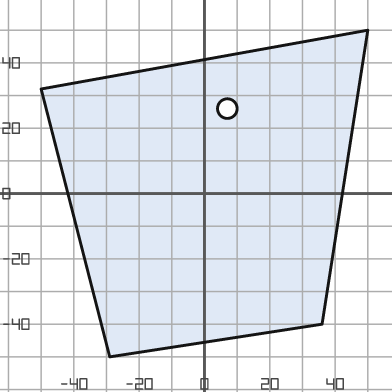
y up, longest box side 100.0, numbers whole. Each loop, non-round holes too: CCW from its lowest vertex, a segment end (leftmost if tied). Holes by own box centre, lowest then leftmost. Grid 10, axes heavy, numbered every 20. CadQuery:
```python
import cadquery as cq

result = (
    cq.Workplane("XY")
    .moveTo(-29.0, -50.0)
    .lineTo(36.0, -40.0)
    .lineTo(50.0, 50.0)
    .lineTo(-50.0, 32.0)
    .close()
    .moveTo(7.0, 26.0)
    .circle(3.0)
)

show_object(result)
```